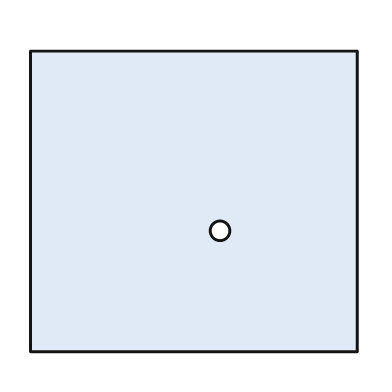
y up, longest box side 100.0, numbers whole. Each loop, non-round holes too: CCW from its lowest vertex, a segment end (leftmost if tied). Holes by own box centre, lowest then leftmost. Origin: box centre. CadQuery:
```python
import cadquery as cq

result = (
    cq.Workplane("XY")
    .moveTo(-50.0, -46.0)
    .lineTo(50.0, -46.0)
    .lineTo(50.0, 46.0)
    .lineTo(-50.0, 46.0)
    .close()
    .moveTo(8.0, -9.0)
    .circle(3.0)
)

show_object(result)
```